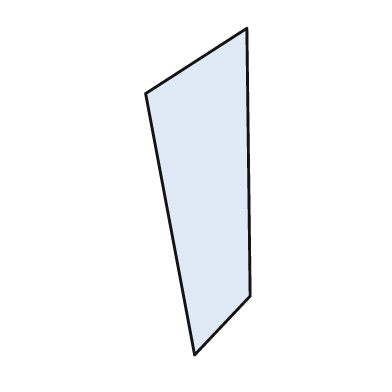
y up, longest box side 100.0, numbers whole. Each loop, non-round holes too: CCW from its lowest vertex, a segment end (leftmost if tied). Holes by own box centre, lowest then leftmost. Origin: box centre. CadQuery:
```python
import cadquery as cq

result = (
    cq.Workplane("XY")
    .moveTo(-1.0, -50.0)
    .lineTo(16.0, -32.0)
    .lineTo(15.0, 50.0)
    .lineTo(-16.0, 30.0)
    .close()
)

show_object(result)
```